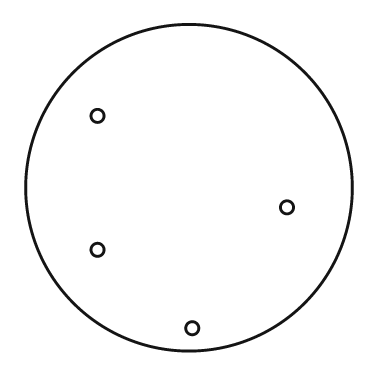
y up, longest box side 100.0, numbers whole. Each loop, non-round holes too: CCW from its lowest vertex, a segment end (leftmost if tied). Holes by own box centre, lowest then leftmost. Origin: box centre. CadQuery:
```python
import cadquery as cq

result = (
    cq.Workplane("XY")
    .moveTo(0.0, 0.0)
    .circle(50.0)
    .moveTo(1.0, -43.0)
    .circle(2.0)
    .moveTo(-28.0, -19.0)
    .circle(2.0)
    .moveTo(30.0, -6.0)
    .circle(2.0)
    .moveTo(-28.0, 22.0)
    .circle(2.0)
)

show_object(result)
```